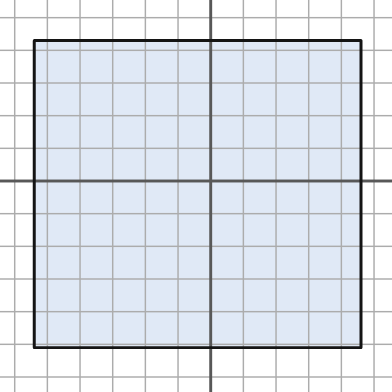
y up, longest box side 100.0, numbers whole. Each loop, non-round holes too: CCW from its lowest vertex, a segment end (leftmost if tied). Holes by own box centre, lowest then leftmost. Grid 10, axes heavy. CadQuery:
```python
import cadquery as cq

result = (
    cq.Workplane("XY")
    .moveTo(-54.0, -51.0)
    .lineTo(46.0, -51.0)
    .lineTo(46.0, 43.0)
    .lineTo(-54.0, 43.0)
    .close()
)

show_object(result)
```